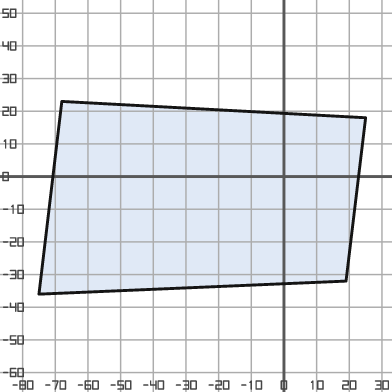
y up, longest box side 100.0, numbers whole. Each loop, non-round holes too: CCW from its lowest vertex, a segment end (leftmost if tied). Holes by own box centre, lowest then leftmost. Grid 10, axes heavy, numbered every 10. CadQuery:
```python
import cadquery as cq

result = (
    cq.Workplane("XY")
    .moveTo(-75.0, -36.0)
    .lineTo(19.0, -32.0)
    .lineTo(25.0, 18.0)
    .lineTo(-68.0, 23.0)
    .close()
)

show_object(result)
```